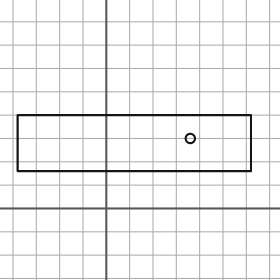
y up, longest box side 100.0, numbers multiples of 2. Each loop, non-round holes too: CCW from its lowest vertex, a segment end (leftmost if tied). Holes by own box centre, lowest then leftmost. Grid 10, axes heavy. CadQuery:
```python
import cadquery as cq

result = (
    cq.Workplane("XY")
    .moveTo(-38.0, 16.0)
    .lineTo(62.0, 16.0)
    .lineTo(62.0, 40.0)
    .lineTo(-38.0, 40.0)
    .close()
    .moveTo(36.0, 30.0)
    .circle(2.0)
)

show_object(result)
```